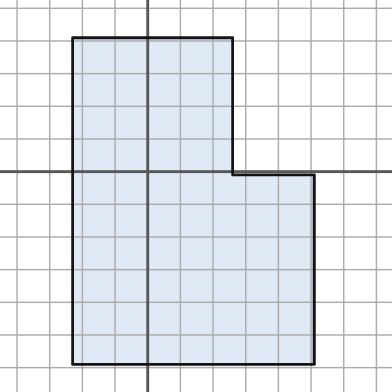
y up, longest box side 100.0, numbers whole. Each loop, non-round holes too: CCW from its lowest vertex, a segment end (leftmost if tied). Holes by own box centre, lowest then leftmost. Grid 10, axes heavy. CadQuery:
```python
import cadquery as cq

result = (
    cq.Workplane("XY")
    .moveTo(-23.0, -59.0)
    .lineTo(51.0, -59.0)
    .lineTo(51.0, -1.0)
    .lineTo(26.0, -1.0)
    .lineTo(26.0, 41.0)
    .lineTo(-23.0, 41.0)
    .close()
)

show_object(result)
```